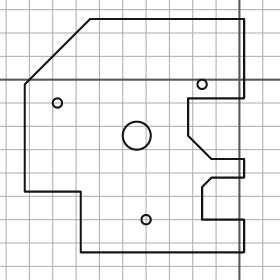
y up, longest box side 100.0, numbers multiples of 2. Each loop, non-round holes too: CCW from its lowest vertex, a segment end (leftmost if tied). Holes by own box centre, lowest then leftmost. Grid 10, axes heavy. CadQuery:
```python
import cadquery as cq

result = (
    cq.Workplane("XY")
    .moveTo(-68.0, -74.0)
    .lineTo(2.0, -74.0)
    .lineTo(2.0, -60.0)
    .lineTo(-16.0, -60.0)
    .lineTo(-16.0, -46.0)
    .lineTo(-12.0, -42.0)
    .lineTo(2.0, -42.0)
    .lineTo(2.0, -34.0)
    .lineTo(-12.0, -34.0)
    .lineTo(-22.0, -24.0)
    .lineTo(-22.0, -8.0)
    .lineTo(2.0, -8.0)
    .lineTo(2.0, 26.0)
    .lineTo(-64.0, 26.0)
    .lineTo(-92.0, -2.0)
    .lineTo(-92.0, -48.0)
    .lineTo(-68.0, -48.0)
    .close()
    .moveTo(-40.0, -60.0)
    .circle(2.0)
    .moveTo(-44.0, -24.0)
    .circle(6.0)
    .moveTo(-78.0, -10.0)
    .circle(2.0)
    .moveTo(-16.0, -2.0)
    .circle(2.0)
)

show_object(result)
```